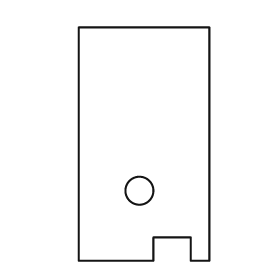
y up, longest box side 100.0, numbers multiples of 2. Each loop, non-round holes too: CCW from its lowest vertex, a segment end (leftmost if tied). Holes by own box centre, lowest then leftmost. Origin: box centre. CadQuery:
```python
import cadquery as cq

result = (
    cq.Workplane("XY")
    .moveTo(-28.0, -50.0)
    .lineTo(4.0, -50.0)
    .lineTo(4.0, -40.0)
    .lineTo(20.0, -40.0)
    .lineTo(20.0, -50.0)
    .lineTo(28.0, -50.0)
    .lineTo(28.0, 50.0)
    .lineTo(-28.0, 50.0)
    .close()
    .moveTo(-2.0, -20.0)
    .circle(6.0)
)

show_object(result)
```